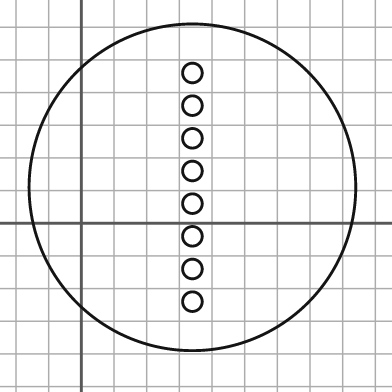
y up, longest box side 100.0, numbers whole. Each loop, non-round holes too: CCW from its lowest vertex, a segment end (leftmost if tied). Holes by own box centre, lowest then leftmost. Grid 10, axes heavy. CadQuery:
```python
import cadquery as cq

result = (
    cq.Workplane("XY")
    .moveTo(34.0, 11.0)
    .circle(50.0)
    .moveTo(34.0, -24.0)
    .circle(3.0)
    .moveTo(34.0, -14.0)
    .circle(3.0)
    .moveTo(34.0, -4.0)
    .circle(3.0)
    .moveTo(34.0, 6.0)
    .circle(3.0)
    .moveTo(34.0, 16.0)
    .circle(3.0)
    .moveTo(34.0, 26.0)
    .circle(3.0)
    .moveTo(34.0, 36.0)
    .circle(3.0)
    .moveTo(34.0, 46.0)
    .circle(3.0)
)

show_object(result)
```